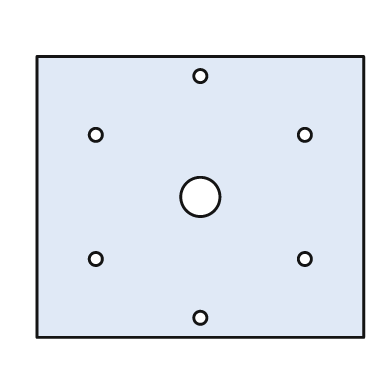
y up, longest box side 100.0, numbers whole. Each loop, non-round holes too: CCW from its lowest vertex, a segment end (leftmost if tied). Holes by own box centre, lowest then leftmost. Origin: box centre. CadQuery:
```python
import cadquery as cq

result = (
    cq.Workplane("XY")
    .moveTo(-50.0, -43.0)
    .lineTo(50.0, -43.0)
    .lineTo(50.0, 43.0)
    .lineTo(-50.0, 43.0)
    .close()
    .moveTo(0.0, -37.0)
    .circle(2.0)
    .moveTo(-32.0, -19.0)
    .circle(2.0)
    .moveTo(32.0, -19.0)
    .circle(2.0)
    .moveTo(0.0, 0.0)
    .circle(6.0)
    .moveTo(-32.0, 19.0)
    .circle(2.0)
    .moveTo(32.0, 19.0)
    .circle(2.0)
    .moveTo(0.0, 37.0)
    .circle(2.0)
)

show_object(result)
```